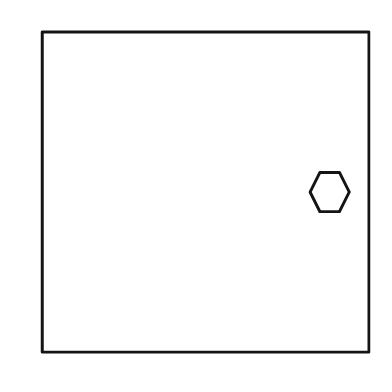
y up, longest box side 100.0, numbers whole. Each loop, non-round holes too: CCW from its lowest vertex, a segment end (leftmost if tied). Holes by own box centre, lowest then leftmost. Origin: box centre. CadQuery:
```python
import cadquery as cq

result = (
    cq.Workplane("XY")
    .moveTo(-50.0, -49.0)
    .lineTo(50.0, -49.0)
    .lineTo(50.0, 49.0)
    .lineTo(-50.0, 49.0)
    .close()
    .moveTo(35.0, -6.0)
    .lineTo(41.0, -6.0)
    .lineTo(44.0, 0.0)
    .lineTo(41.0, 6.0)
    .lineTo(35.0, 6.0)
    .lineTo(32.0, 0.0)
    .close()
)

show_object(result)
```